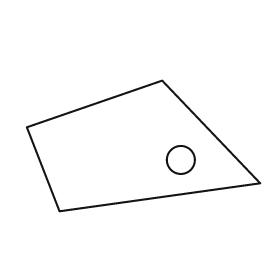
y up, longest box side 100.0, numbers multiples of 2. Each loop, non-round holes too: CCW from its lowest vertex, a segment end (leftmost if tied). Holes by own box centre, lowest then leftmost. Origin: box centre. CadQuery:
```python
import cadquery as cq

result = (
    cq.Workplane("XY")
    .moveTo(-36.0, -28.0)
    .lineTo(50.0, -16.0)
    .lineTo(8.0, 28.0)
    .lineTo(-50.0, 8.0)
    .close()
    .moveTo(16.0, -6.0)
    .circle(6.0)
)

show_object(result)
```